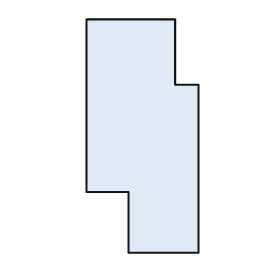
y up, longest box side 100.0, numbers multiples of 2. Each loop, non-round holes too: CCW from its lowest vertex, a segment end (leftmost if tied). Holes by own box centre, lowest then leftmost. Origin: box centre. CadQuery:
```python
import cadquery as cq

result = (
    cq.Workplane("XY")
    .moveTo(-6.0, -50.0)
    .lineTo(24.0, -50.0)
    .lineTo(24.0, 22.0)
    .lineTo(14.0, 22.0)
    .lineTo(14.0, 50.0)
    .lineTo(-24.0, 50.0)
    .lineTo(-24.0, -24.0)
    .lineTo(-6.0, -24.0)
    .close()
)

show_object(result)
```